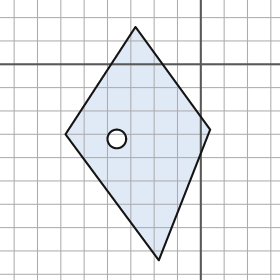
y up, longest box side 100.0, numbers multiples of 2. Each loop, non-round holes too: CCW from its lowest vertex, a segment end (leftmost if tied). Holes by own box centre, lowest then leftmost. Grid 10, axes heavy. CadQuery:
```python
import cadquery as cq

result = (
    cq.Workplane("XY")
    .moveTo(-18.0, -84.0)
    .lineTo(4.0, -28.0)
    .lineTo(-28.0, 16.0)
    .lineTo(-58.0, -30.0)
    .close()
    .moveTo(-36.0, -32.0)
    .circle(4.0)
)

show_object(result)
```